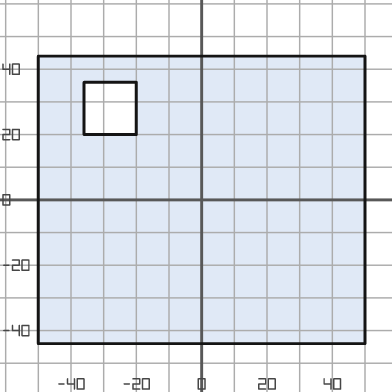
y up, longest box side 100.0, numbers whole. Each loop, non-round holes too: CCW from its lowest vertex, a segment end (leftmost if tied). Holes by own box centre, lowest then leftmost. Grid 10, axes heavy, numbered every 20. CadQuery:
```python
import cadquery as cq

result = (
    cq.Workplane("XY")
    .moveTo(-50.0, -44.0)
    .lineTo(50.0, -44.0)
    .lineTo(50.0, 44.0)
    .lineTo(-50.0, 44.0)
    .close()
    .moveTo(-36.0, 20.0)
    .lineTo(-20.0, 20.0)
    .lineTo(-20.0, 36.0)
    .lineTo(-36.0, 36.0)
    .close()
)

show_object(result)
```